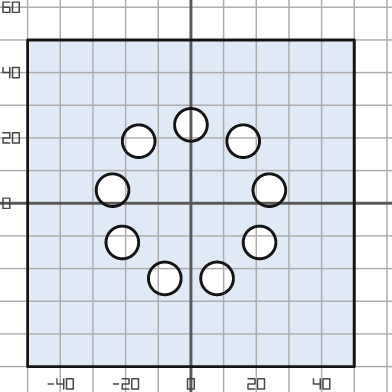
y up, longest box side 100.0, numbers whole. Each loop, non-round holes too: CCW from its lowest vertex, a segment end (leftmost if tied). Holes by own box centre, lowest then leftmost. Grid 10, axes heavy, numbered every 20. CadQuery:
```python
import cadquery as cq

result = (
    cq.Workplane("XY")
    .moveTo(-50.0, -50.0)
    .lineTo(50.0, -50.0)
    .lineTo(50.0, 50.0)
    .lineTo(-50.0, 50.0)
    .close()
    .moveTo(-8.0, -23.0)
    .circle(5.0)
    .moveTo(8.0, -23.0)
    .circle(5.0)
    .moveTo(-21.0, -12.0)
    .circle(5.0)
    .moveTo(21.0, -12.0)
    .circle(5.0)
    .moveTo(-24.0, 4.0)
    .circle(5.0)
    .moveTo(24.0, 4.0)
    .circle(5.0)
    .moveTo(-16.0, 19.0)
    .circle(5.0)
    .moveTo(16.0, 19.0)
    .circle(5.0)
    .moveTo(0.0, 24.0)
    .circle(5.0)
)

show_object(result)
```